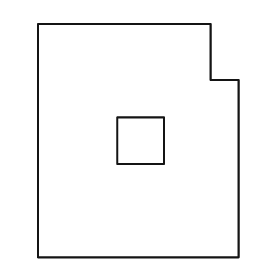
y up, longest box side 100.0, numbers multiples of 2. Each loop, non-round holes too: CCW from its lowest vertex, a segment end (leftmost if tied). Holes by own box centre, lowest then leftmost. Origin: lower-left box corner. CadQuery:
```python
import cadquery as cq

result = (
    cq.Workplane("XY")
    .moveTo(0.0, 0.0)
    .lineTo(86.0, 0.0)
    .lineTo(86.0, 76.0)
    .lineTo(74.0, 76.0)
    .lineTo(74.0, 100.0)
    .lineTo(0.0, 100.0)
    .close()
    .moveTo(34.0, 40.0)
    .lineTo(54.0, 40.0)
    .lineTo(54.0, 60.0)
    .lineTo(34.0, 60.0)
    .close()
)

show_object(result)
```